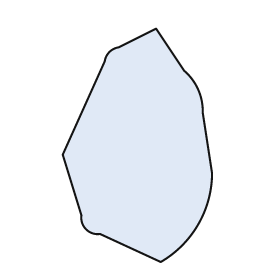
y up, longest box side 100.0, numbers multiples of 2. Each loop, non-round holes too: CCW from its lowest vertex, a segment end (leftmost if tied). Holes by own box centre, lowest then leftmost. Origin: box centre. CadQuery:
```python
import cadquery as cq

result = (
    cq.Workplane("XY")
    .moveTo(10.0, -50.0)
    .threePointArc((26.0, -34.0), (32.0, -12.0))
    .lineTo(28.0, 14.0)
    .threePointArc((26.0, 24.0), (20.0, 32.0))
    .lineTo(8.0, 50.0)
    .lineTo(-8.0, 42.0)
    .threePointArc((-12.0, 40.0), (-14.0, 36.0))
    .lineTo(-32.0, -4.0)
    .lineTo(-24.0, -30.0)
    .threePointArc((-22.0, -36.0), (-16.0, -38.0))
    .close()
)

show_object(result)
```